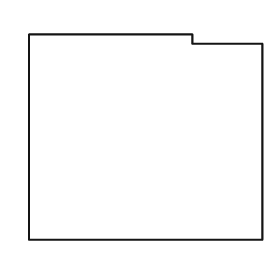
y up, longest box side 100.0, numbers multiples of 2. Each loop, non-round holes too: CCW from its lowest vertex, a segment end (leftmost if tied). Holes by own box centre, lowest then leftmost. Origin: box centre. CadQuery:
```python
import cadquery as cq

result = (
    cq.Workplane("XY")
    .moveTo(-50.0, -44.0)
    .lineTo(50.0, -44.0)
    .lineTo(50.0, 40.0)
    .lineTo(20.0, 40.0)
    .lineTo(20.0, 44.0)
    .lineTo(-50.0, 44.0)
    .close()
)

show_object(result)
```